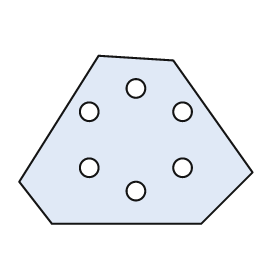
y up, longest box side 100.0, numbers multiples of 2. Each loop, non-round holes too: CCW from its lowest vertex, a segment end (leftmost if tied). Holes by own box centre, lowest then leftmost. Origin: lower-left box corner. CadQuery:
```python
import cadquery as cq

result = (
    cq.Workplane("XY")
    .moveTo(14.0, 0.0)
    .lineTo(78.0, 0.0)
    .lineTo(100.0, 22.0)
    .lineTo(66.0, 70.0)
    .lineTo(34.0, 72.0)
    .lineTo(0.0, 18.0)
    .close()
    .moveTo(50.0, 14.0)
    .circle(4.0)
    .moveTo(30.0, 24.0)
    .circle(4.0)
    .moveTo(70.0, 24.0)
    .circle(4.0)
    .moveTo(30.0, 48.0)
    .circle(4.0)
    .moveTo(70.0, 48.0)
    .circle(4.0)
    .moveTo(50.0, 58.0)
    .circle(4.0)
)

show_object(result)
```